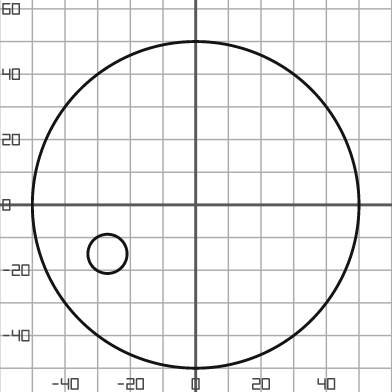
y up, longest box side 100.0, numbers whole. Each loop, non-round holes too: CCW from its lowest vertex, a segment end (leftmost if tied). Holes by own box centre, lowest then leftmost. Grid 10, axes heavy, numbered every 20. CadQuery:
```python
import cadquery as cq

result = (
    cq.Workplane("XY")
    .moveTo(0.0, 0.0)
    .circle(50.0)
    .moveTo(-27.0, -15.0)
    .circle(6.0)
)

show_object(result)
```